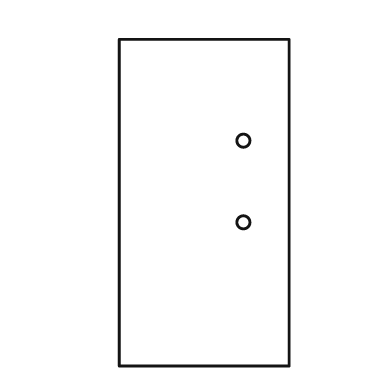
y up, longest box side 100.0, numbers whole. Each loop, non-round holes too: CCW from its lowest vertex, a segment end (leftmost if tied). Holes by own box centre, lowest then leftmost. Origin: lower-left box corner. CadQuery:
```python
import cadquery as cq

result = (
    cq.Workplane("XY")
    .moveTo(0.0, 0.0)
    .lineTo(52.0, 0.0)
    .lineTo(52.0, 100.0)
    .lineTo(0.0, 100.0)
    .close()
    .moveTo(38.0, 44.0)
    .circle(2.0)
    .moveTo(38.0, 69.0)
    .circle(2.0)
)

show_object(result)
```